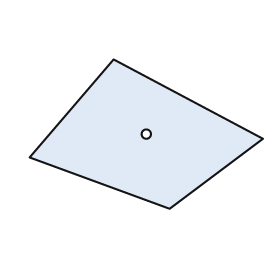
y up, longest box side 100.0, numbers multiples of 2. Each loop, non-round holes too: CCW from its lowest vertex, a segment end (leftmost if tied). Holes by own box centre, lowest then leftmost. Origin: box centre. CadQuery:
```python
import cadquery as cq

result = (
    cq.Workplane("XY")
    .moveTo(10.0, -32.0)
    .lineTo(50.0, -2.0)
    .lineTo(-14.0, 32.0)
    .lineTo(-50.0, -10.0)
    .close()
    .moveTo(0.0, 0.0)
    .circle(2.0)
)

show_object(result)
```